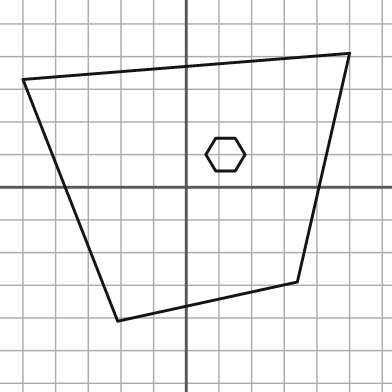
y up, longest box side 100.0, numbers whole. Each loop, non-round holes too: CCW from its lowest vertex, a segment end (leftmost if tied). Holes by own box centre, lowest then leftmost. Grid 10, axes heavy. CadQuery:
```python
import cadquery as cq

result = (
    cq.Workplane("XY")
    .moveTo(-21.0, -41.0)
    .lineTo(34.0, -29.0)
    .lineTo(50.0, 41.0)
    .lineTo(-50.0, 33.0)
    .close()
    .moveTo(9.0, 5.0)
    .lineTo(15.0, 5.0)
    .lineTo(18.0, 10.0)
    .lineTo(15.0, 15.0)
    .lineTo(9.0, 15.0)
    .lineTo(6.0, 10.0)
    .close()
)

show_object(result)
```